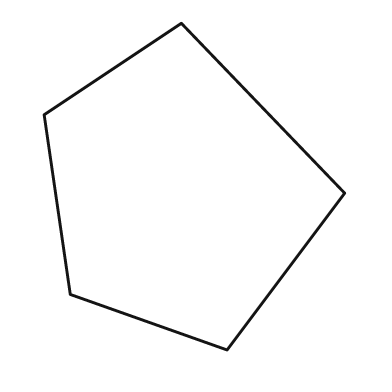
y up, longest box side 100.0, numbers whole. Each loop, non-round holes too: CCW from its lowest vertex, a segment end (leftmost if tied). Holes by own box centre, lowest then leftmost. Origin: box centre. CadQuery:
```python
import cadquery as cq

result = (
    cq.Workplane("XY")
    .moveTo(10.0, -50.0)
    .lineTo(46.0, -2.0)
    .lineTo(-4.0, 50.0)
    .lineTo(-46.0, 22.0)
    .lineTo(-38.0, -33.0)
    .close()
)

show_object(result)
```